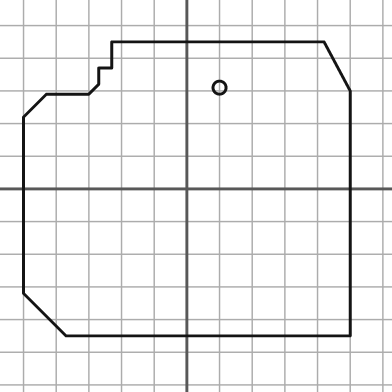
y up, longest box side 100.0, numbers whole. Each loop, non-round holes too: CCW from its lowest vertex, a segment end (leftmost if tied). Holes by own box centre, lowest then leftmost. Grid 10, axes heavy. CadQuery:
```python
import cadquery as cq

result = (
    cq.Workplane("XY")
    .moveTo(-37.0, -45.0)
    .lineTo(50.0, -45.0)
    .lineTo(50.0, 30.0)
    .lineTo(42.0, 45.0)
    .lineTo(-23.0, 45.0)
    .lineTo(-23.0, 37.0)
    .lineTo(-27.0, 37.0)
    .lineTo(-27.0, 32.0)
    .lineTo(-30.0, 29.0)
    .lineTo(-43.0, 29.0)
    .lineTo(-50.0, 22.0)
    .lineTo(-50.0, -32.0)
    .close()
    .moveTo(10.0, 31.0)
    .circle(2.0)
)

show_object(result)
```